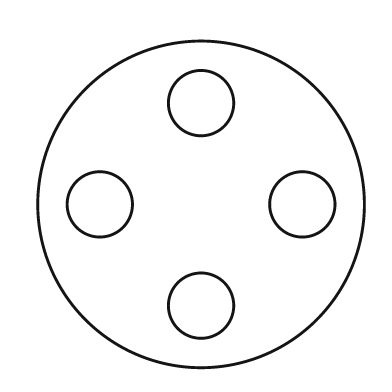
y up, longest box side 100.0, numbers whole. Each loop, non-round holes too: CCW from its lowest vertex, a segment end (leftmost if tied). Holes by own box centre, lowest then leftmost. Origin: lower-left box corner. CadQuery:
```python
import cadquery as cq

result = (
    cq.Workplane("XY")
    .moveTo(50.0, 50.0)
    .circle(50.0)
    .moveTo(50.0, 19.0)
    .circle(10.0)
    .moveTo(19.0, 50.0)
    .circle(10.0)
    .moveTo(81.0, 50.0)
    .circle(10.0)
    .moveTo(50.0, 81.0)
    .circle(10.0)
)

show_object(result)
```